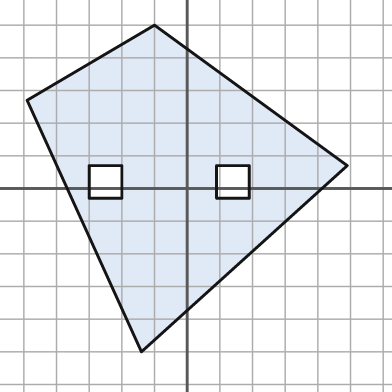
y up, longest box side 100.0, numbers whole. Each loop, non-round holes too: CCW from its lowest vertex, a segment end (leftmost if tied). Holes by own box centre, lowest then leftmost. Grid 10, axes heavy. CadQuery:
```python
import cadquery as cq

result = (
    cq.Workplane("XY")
    .moveTo(-14.0, -50.0)
    .lineTo(49.0, 7.0)
    .lineTo(-10.0, 50.0)
    .lineTo(-49.0, 27.0)
    .close()
    .moveTo(-30.0, -3.0)
    .lineTo(-20.0, -3.0)
    .lineTo(-20.0, 7.0)
    .lineTo(-30.0, 7.0)
    .close()
    .moveTo(9.0, -3.0)
    .lineTo(19.0, -3.0)
    .lineTo(19.0, 7.0)
    .lineTo(9.0, 7.0)
    .close()
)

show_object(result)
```